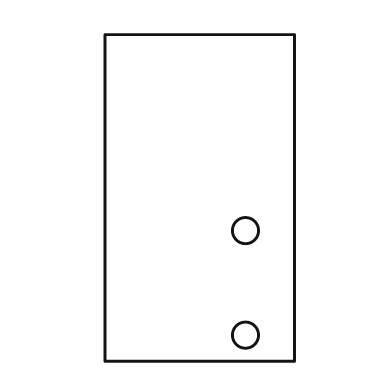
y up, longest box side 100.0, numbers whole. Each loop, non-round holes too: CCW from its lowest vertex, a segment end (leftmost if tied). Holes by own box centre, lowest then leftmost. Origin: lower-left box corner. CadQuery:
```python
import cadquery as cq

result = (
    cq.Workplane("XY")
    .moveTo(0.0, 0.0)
    .lineTo(58.0, 0.0)
    .lineTo(58.0, 100.0)
    .lineTo(0.0, 100.0)
    .close()
    .moveTo(43.0, 8.0)
    .circle(4.0)
    .moveTo(43.0, 40.0)
    .circle(4.0)
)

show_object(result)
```